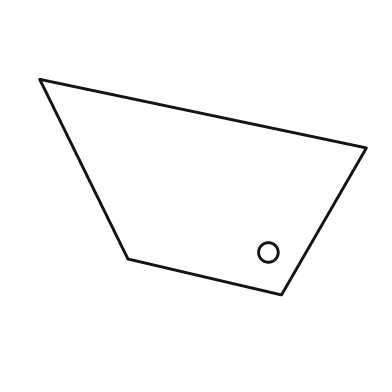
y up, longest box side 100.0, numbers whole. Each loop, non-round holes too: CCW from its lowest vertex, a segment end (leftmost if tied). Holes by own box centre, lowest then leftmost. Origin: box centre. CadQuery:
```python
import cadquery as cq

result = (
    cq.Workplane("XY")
    .moveTo(24.0, -33.0)
    .lineTo(50.0, 12.0)
    .lineTo(-50.0, 33.0)
    .lineTo(-23.0, -22.0)
    .close()
    .moveTo(20.0, -20.0)
    .circle(3.0)
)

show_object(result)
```